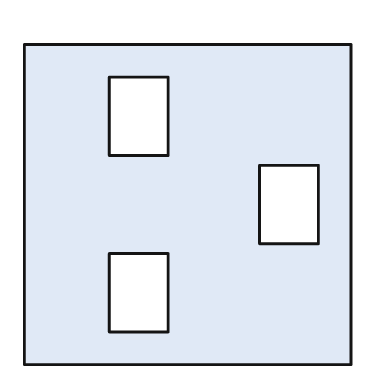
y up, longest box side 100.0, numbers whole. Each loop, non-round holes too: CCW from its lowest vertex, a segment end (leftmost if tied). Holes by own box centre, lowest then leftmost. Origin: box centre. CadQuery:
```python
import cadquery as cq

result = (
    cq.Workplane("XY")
    .moveTo(-50.0, -49.0)
    .lineTo(50.0, -49.0)
    .lineTo(50.0, 49.0)
    .lineTo(-50.0, 49.0)
    .close()
    .moveTo(-24.0, -39.0)
    .lineTo(-6.0, -39.0)
    .lineTo(-6.0, -15.0)
    .lineTo(-24.0, -15.0)
    .close()
    .moveTo(22.0, -12.0)
    .lineTo(40.0, -12.0)
    .lineTo(40.0, 12.0)
    .lineTo(22.0, 12.0)
    .close()
    .moveTo(-24.0, 15.0)
    .lineTo(-6.0, 15.0)
    .lineTo(-6.0, 39.0)
    .lineTo(-24.0, 39.0)
    .close()
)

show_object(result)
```